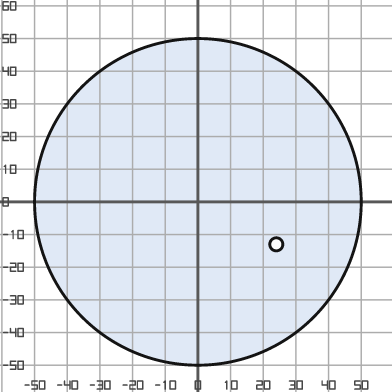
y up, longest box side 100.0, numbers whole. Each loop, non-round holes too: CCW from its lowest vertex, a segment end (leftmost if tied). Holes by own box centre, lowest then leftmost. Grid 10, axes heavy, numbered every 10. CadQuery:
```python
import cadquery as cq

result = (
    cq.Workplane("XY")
    .moveTo(0.0, 0.0)
    .circle(50.0)
    .moveTo(24.0, -13.0)
    .circle(2.0)
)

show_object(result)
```